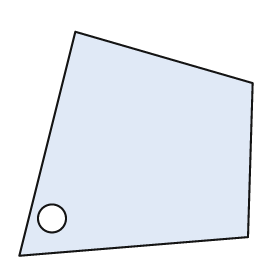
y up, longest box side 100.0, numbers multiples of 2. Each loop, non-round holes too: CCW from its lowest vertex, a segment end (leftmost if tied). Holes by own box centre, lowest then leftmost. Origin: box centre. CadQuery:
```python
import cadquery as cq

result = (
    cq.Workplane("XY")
    .moveTo(-50.0, -48.0)
    .lineTo(48.0, -40.0)
    .lineTo(50.0, 26.0)
    .lineTo(-26.0, 48.0)
    .close()
    .moveTo(-36.0, -32.0)
    .circle(6.0)
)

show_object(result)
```